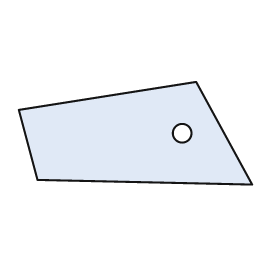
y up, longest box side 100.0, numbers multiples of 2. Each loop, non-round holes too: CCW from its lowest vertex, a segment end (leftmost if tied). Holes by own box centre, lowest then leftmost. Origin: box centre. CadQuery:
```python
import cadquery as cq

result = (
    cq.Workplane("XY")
    .moveTo(50.0, -22.0)
    .lineTo(26.0, 22.0)
    .lineTo(-50.0, 10.0)
    .lineTo(-42.0, -20.0)
    .close()
    .moveTo(20.0, 0.0)
    .circle(4.0)
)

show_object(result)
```